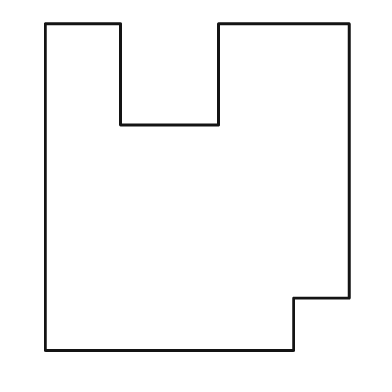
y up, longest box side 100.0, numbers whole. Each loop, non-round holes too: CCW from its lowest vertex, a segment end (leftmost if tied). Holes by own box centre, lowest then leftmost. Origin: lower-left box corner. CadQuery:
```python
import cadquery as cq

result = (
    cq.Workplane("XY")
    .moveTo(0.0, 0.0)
    .lineTo(76.0, 0.0)
    .lineTo(76.0, 16.0)
    .lineTo(93.0, 16.0)
    .lineTo(93.0, 100.0)
    .lineTo(53.0, 100.0)
    .lineTo(53.0, 69.0)
    .lineTo(23.0, 69.0)
    .lineTo(23.0, 100.0)
    .lineTo(0.0, 100.0)
    .close()
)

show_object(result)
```